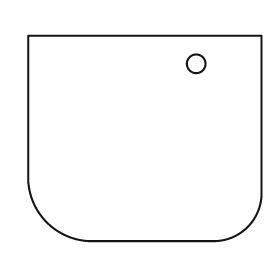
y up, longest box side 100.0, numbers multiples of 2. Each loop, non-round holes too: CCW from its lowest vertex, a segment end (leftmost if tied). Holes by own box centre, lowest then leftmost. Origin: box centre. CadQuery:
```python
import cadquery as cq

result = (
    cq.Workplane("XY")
    .moveTo(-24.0, -44.0)
    .lineTo(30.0, -44.0)
    .threePointArc((44.0, -38.0), (50.0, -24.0))
    .lineTo(50.0, 44.0)
    .lineTo(-50.0, 44.0)
    .lineTo(-50.0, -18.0)
    .threePointArc((-42.0, -36.0), (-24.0, -44.0))
    .close()
    .moveTo(22.0, 32.0)
    .circle(4.0)
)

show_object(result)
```